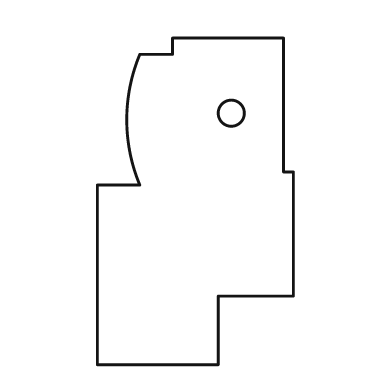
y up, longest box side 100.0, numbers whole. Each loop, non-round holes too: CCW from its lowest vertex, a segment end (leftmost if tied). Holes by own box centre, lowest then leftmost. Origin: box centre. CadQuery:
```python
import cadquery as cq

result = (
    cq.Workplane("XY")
    .moveTo(-30.0, -50.0)
    .lineTo(7.0, -50.0)
    .lineTo(7.0, -29.0)
    .lineTo(30.0, -29.0)
    .lineTo(30.0, 9.0)
    .lineTo(27.0, 9.0)
    .lineTo(27.0, 50.0)
    .lineTo(-7.0, 50.0)
    .lineTo(-7.0, 45.0)
    .lineTo(-17.0, 45.0)
    .threePointArc((-21.0, 25.0), (-17.0, 5.0))
    .lineTo(-30.0, 5.0)
    .close()
    .moveTo(11.0, 27.0)
    .circle(4.0)
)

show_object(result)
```